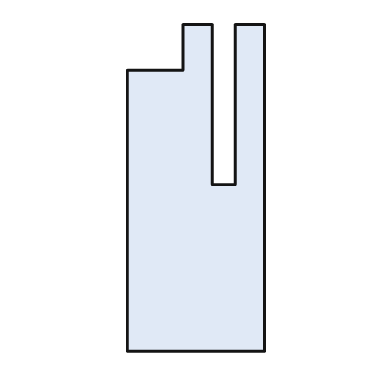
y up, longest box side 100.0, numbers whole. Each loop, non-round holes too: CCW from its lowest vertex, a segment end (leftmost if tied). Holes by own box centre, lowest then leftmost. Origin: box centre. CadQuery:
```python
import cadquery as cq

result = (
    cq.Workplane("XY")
    .moveTo(-21.0, -50.0)
    .lineTo(21.0, -50.0)
    .lineTo(21.0, 50.0)
    .lineTo(12.0, 50.0)
    .lineTo(12.0, 1.0)
    .lineTo(5.0, 1.0)
    .lineTo(5.0, 50.0)
    .lineTo(-4.0, 50.0)
    .lineTo(-4.0, 36.0)
    .lineTo(-21.0, 36.0)
    .close()
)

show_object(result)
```